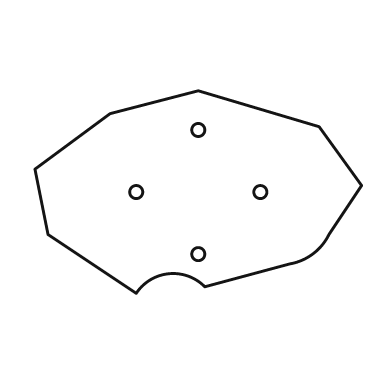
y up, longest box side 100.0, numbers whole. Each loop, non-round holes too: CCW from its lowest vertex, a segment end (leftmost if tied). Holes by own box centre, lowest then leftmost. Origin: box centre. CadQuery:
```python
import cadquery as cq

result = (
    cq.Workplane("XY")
    .moveTo(-19.0, -31.0)
    .threePointArc((-9.0, -25.0), (2.0, -29.0))
    .lineTo(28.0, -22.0)
    .threePointArc((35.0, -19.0), (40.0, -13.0))
    .lineTo(50.0, 2.0)
    .lineTo(37.0, 20.0)
    .lineTo(0.0, 31.0)
    .lineTo(-27.0, 24.0)
    .lineTo(-50.0, 7.0)
    .lineTo(-46.0, -13.0)
    .close()
    .moveTo(0.0, -19.0)
    .circle(2.0)
    .moveTo(-19.0, 0.0)
    .circle(2.0)
    .moveTo(19.0, 0.0)
    .circle(2.0)
    .moveTo(0.0, 19.0)
    .circle(2.0)
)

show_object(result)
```